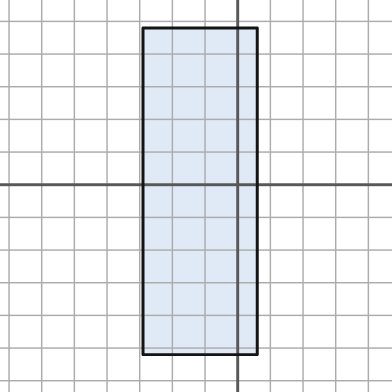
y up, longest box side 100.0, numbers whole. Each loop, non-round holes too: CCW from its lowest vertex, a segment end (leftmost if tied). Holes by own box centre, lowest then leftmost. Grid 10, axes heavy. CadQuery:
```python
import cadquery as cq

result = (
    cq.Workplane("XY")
    .moveTo(-29.0, -52.0)
    .lineTo(6.0, -52.0)
    .lineTo(6.0, 48.0)
    .lineTo(-29.0, 48.0)
    .close()
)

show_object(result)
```